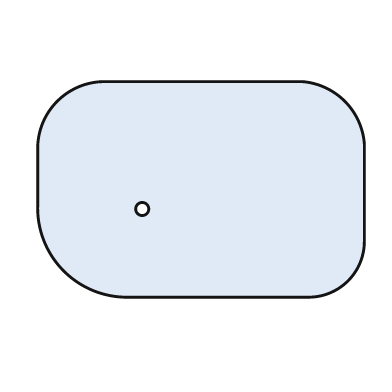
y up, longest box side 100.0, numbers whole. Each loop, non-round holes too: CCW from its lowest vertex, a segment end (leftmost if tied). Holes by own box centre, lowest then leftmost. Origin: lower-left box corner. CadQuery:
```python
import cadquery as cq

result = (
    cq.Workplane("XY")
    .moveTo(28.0, 0.0)
    .lineTo(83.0, 0.0)
    .threePointArc((95.0, 5.0), (100.0, 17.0))
    .lineTo(100.0, 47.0)
    .threePointArc((94.0, 60.0), (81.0, 66.0))
    .lineTo(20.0, 66.0)
    .threePointArc((6.0, 60.0), (0.0, 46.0))
    .lineTo(0.0, 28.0)
    .threePointArc((8.0, 8.0), (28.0, 0.0))
    .close()
    .moveTo(32.0, 27.0)
    .circle(2.0)
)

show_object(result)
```